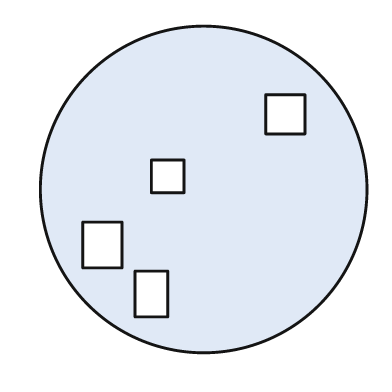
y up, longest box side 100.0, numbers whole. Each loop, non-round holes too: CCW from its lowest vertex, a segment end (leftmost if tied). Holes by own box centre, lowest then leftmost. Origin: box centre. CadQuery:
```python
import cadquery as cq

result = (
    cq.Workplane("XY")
    .moveTo(0.0, 0.0)
    .circle(50.0)
    .moveTo(-21.0, -39.0)
    .lineTo(-11.0, -39.0)
    .lineTo(-11.0, -25.0)
    .lineTo(-21.0, -25.0)
    .close()
    .moveTo(-37.0, -24.0)
    .lineTo(-25.0, -24.0)
    .lineTo(-25.0, -10.0)
    .lineTo(-37.0, -10.0)
    .close()
    .moveTo(-16.0, -1.0)
    .lineTo(-6.0, -1.0)
    .lineTo(-6.0, 9.0)
    .lineTo(-16.0, 9.0)
    .close()
    .moveTo(19.0, 17.0)
    .lineTo(31.0, 17.0)
    .lineTo(31.0, 29.0)
    .lineTo(19.0, 29.0)
    .close()
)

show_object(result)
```